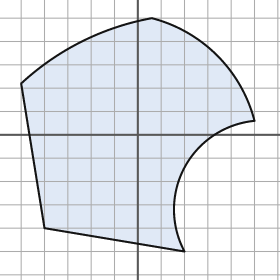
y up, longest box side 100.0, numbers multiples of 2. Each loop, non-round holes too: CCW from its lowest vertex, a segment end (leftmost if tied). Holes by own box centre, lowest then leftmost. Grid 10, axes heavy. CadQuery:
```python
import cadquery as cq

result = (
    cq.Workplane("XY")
    .moveTo(20.0, -50.0)
    .threePointArc((20.0, -14.0), (50.0, 6.0))
    .threePointArc((34.0, 34.0), (6.0, 50.0))
    .threePointArc((-24.0, 40.0), (-50.0, 22.0))
    .lineTo(-40.0, -40.0)
    .close()
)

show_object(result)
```